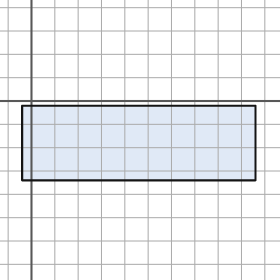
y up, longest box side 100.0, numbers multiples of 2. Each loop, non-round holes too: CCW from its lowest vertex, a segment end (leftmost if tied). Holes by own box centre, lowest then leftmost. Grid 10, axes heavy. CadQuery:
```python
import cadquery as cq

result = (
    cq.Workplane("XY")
    .moveTo(-4.0, -34.0)
    .lineTo(96.0, -34.0)
    .lineTo(96.0, -2.0)
    .lineTo(-4.0, -2.0)
    .close()
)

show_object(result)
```